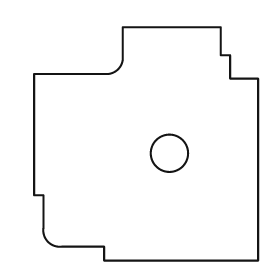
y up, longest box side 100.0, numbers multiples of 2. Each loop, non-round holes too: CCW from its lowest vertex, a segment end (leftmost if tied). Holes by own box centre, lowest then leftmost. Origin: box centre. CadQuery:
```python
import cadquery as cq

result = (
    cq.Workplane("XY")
    .moveTo(-18.0, -50.0)
    .lineTo(48.0, -50.0)
    .lineTo(48.0, 28.0)
    .lineTo(36.0, 28.0)
    .lineTo(36.0, 38.0)
    .lineTo(32.0, 38.0)
    .lineTo(32.0, 50.0)
    .lineTo(-10.0, 50.0)
    .lineTo(-10.0, 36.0)
    .threePointArc((-12.0, 32.0), (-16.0, 30.0))
    .lineTo(-48.0, 30.0)
    .lineTo(-48.0, -22.0)
    .lineTo(-44.0, -22.0)
    .lineTo(-44.0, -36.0)
    .threePointArc((-42.0, -42.0), (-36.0, -44.0))
    .lineTo(-18.0, -44.0)
    .close()
    .moveTo(10.0, -4.0)
    .circle(8.0)
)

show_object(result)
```